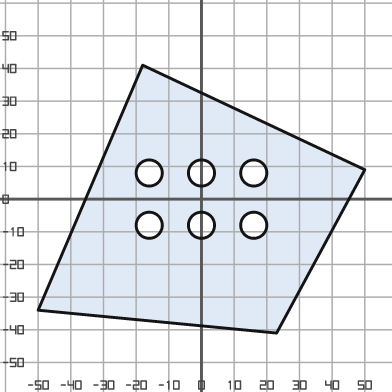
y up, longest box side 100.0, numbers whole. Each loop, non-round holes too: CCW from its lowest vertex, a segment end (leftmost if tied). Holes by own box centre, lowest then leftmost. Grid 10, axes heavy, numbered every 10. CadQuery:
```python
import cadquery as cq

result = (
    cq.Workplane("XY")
    .moveTo(23.0, -41.0)
    .lineTo(50.0, 9.0)
    .lineTo(-18.0, 41.0)
    .lineTo(-50.0, -34.0)
    .close()
    .moveTo(-16.0, -8.0)
    .circle(4.0)
    .moveTo(0.0, -8.0)
    .circle(4.0)
    .moveTo(16.0, -8.0)
    .circle(4.0)
    .moveTo(-16.0, 8.0)
    .circle(4.0)
    .moveTo(0.0, 8.0)
    .circle(4.0)
    .moveTo(16.0, 8.0)
    .circle(4.0)
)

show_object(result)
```